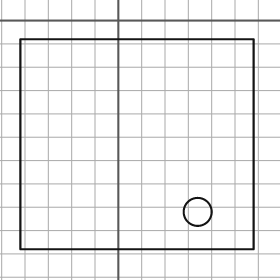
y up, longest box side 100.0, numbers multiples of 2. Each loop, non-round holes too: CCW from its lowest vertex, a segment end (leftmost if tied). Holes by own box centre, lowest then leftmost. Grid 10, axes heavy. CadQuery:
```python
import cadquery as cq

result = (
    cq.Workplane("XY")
    .moveTo(-42.0, -98.0)
    .lineTo(58.0, -98.0)
    .lineTo(58.0, -8.0)
    .lineTo(-42.0, -8.0)
    .close()
    .moveTo(34.0, -82.0)
    .circle(6.0)
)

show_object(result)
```